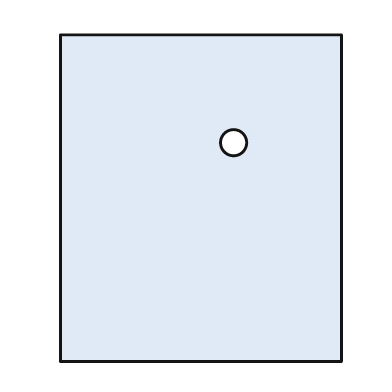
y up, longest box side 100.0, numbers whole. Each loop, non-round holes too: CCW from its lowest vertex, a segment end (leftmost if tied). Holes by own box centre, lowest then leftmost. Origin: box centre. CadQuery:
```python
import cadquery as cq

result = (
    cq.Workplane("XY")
    .moveTo(-43.0, -50.0)
    .lineTo(43.0, -50.0)
    .lineTo(43.0, 50.0)
    .lineTo(-43.0, 50.0)
    .close()
    .moveTo(10.0, 17.0)
    .circle(4.0)
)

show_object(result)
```